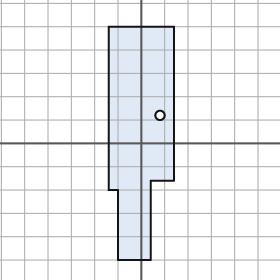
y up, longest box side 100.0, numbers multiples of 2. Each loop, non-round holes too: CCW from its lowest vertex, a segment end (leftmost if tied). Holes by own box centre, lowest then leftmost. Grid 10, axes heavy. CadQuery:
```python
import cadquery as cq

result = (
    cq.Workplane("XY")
    .moveTo(-10.0, -50.0)
    .lineTo(4.0, -50.0)
    .lineTo(4.0, -16.0)
    .lineTo(14.0, -16.0)
    .lineTo(14.0, 50.0)
    .lineTo(-14.0, 50.0)
    .lineTo(-14.0, -20.0)
    .lineTo(-10.0, -20.0)
    .close()
    .moveTo(8.0, 12.0)
    .circle(2.0)
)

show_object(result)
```